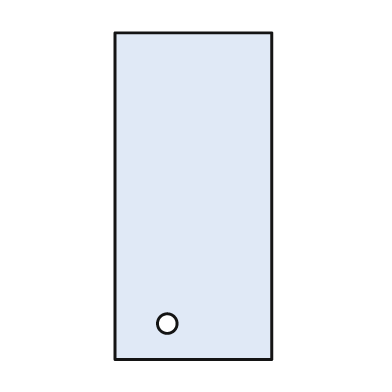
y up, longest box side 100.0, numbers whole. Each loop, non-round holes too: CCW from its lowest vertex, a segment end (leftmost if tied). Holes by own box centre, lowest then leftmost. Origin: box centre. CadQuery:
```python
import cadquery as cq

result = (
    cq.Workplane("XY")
    .moveTo(-24.0, -50.0)
    .lineTo(24.0, -50.0)
    .lineTo(24.0, 50.0)
    .lineTo(-24.0, 50.0)
    .close()
    .moveTo(-8.0, -39.0)
    .circle(3.0)
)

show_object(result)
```